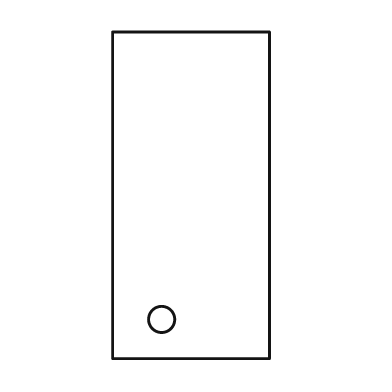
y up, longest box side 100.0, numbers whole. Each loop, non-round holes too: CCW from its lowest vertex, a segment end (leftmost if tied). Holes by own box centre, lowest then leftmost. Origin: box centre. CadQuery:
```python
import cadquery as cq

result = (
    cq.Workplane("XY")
    .moveTo(-24.0, -50.0)
    .lineTo(24.0, -50.0)
    .lineTo(24.0, 50.0)
    .lineTo(-24.0, 50.0)
    .close()
    .moveTo(-9.0, -38.0)
    .circle(4.0)
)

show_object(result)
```